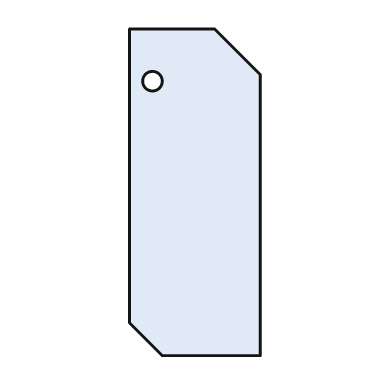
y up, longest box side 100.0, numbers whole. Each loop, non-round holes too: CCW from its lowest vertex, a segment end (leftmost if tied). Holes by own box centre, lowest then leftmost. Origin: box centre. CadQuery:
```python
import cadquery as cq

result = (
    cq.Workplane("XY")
    .moveTo(-10.0, -50.0)
    .lineTo(20.0, -50.0)
    .lineTo(20.0, 36.0)
    .lineTo(6.0, 50.0)
    .lineTo(-20.0, 50.0)
    .lineTo(-20.0, -40.0)
    .close()
    .moveTo(-13.0, 34.0)
    .circle(3.0)
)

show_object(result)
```